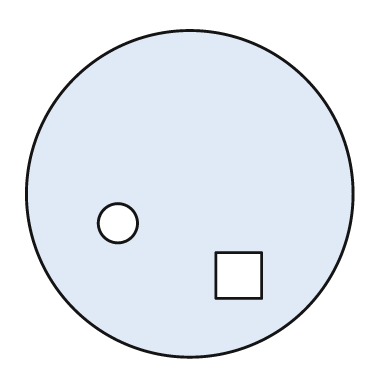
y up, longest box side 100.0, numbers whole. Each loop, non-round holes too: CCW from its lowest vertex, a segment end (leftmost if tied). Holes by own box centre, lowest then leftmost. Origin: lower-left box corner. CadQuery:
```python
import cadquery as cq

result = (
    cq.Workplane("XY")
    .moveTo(50.0, 50.0)
    .circle(50.0)
    .moveTo(58.0, 18.0)
    .lineTo(72.0, 18.0)
    .lineTo(72.0, 32.0)
    .lineTo(58.0, 32.0)
    .close()
    .moveTo(28.0, 41.0)
    .circle(6.0)
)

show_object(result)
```